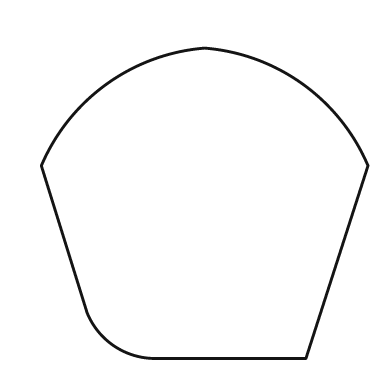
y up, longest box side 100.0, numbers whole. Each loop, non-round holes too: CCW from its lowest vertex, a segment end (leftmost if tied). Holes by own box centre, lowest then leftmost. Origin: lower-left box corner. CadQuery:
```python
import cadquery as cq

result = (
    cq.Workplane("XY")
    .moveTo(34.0, 0.0)
    .lineTo(81.0, 0.0)
    .lineTo(100.0, 59.0)
    .threePointArc((80.0, 84.0), (50.0, 95.0))
    .threePointArc((20.0, 84.0), (0.0, 59.0))
    .lineTo(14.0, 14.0)
    .threePointArc((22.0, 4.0), (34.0, 0.0))
    .close()
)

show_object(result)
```